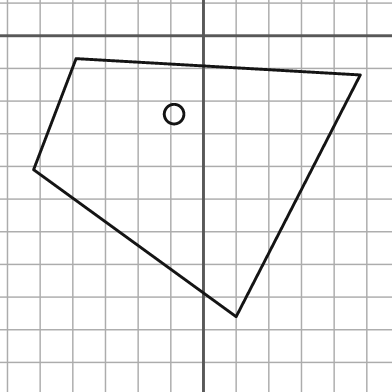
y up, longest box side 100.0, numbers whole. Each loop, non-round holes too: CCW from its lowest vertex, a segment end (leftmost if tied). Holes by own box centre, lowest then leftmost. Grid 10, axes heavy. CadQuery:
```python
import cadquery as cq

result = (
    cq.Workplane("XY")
    .moveTo(10.0, -86.0)
    .lineTo(48.0, -12.0)
    .lineTo(-39.0, -7.0)
    .lineTo(-52.0, -41.0)
    .close()
    .moveTo(-9.0, -24.0)
    .circle(3.0)
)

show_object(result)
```